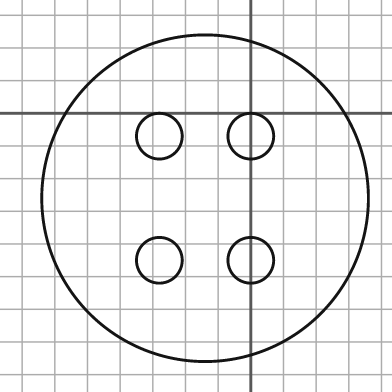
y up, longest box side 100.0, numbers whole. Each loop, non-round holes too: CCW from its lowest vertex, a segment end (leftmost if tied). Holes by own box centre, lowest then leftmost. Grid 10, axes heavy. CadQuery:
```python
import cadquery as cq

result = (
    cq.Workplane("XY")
    .moveTo(-14.0, -26.0)
    .circle(50.0)
    .moveTo(-28.0, -45.0)
    .circle(7.0)
    .moveTo(0.0, -45.0)
    .circle(7.0)
    .moveTo(-28.0, -7.0)
    .circle(7.0)
    .moveTo(0.0, -7.0)
    .circle(7.0)
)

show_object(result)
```